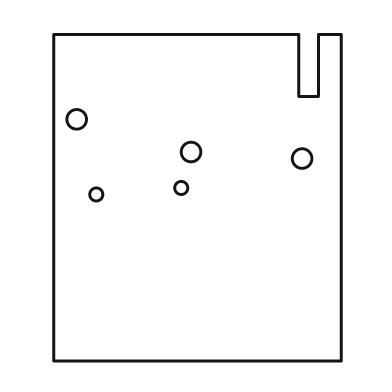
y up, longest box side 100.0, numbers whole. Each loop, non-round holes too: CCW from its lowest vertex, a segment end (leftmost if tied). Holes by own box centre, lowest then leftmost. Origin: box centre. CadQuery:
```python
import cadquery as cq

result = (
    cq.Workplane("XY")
    .moveTo(-44.0, -50.0)
    .lineTo(44.0, -50.0)
    .lineTo(44.0, 50.0)
    .lineTo(37.0, 50.0)
    .lineTo(37.0, 31.0)
    .lineTo(31.0, 31.0)
    .lineTo(31.0, 50.0)
    .lineTo(-44.0, 50.0)
    .close()
    .moveTo(-31.0, 1.0)
    .circle(2.0)
    .moveTo(-5.0, 3.0)
    .circle(2.0)
    .moveTo(32.0, 12.0)
    .circle(3.0)
    .moveTo(-2.0, 14.0)
    .circle(3.0)
    .moveTo(-37.0, 24.0)
    .circle(3.0)
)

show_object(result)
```